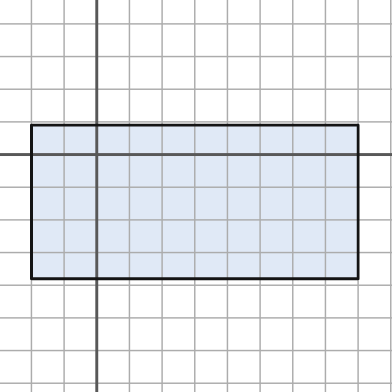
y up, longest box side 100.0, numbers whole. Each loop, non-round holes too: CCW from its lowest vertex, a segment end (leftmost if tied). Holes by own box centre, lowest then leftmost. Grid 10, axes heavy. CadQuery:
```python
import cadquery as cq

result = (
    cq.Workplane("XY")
    .moveTo(-20.0, -38.0)
    .lineTo(80.0, -38.0)
    .lineTo(80.0, 9.0)
    .lineTo(-20.0, 9.0)
    .close()
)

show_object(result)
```